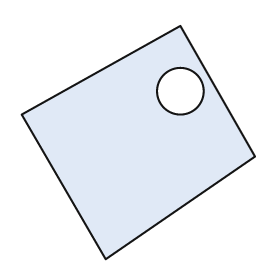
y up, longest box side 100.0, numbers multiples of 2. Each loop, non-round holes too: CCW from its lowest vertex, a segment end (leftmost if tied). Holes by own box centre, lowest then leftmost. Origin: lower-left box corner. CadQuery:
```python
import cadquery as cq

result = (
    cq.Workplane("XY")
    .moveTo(36.0, 0.0)
    .lineTo(100.0, 44.0)
    .lineTo(68.0, 100.0)
    .lineTo(0.0, 62.0)
    .close()
    .moveTo(68.0, 72.0)
    .circle(10.0)
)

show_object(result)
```